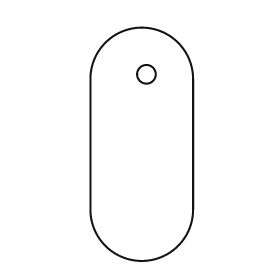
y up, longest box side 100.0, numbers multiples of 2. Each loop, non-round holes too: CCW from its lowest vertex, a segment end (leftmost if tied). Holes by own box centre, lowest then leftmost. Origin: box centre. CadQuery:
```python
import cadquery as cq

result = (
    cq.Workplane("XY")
    .moveTo(-22.0, -28.0)
    .threePointArc((0.0, -50.0), (22.0, -28.0))
    .lineTo(22.0, 28.0)
    .threePointArc((0.0, 50.0), (-22.0, 28.0))
    .close()
    .moveTo(2.0, 30.0)
    .circle(4.0)
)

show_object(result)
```